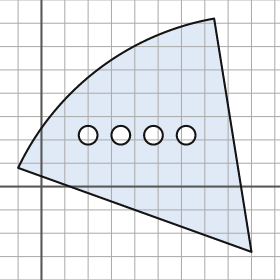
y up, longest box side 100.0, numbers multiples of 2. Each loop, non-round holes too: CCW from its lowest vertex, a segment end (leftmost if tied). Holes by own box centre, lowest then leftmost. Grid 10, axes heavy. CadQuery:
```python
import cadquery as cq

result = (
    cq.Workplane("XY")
    .moveTo(90.0, -28.0)
    .lineTo(74.0, 72.0)
    .threePointArc((24.0, 50.0), (-10.0, 8.0))
    .close()
    .moveTo(20.0, 22.0)
    .circle(4.0)
    .moveTo(34.0, 22.0)
    .circle(4.0)
    .moveTo(48.0, 22.0)
    .circle(4.0)
    .moveTo(62.0, 22.0)
    .circle(4.0)
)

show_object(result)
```